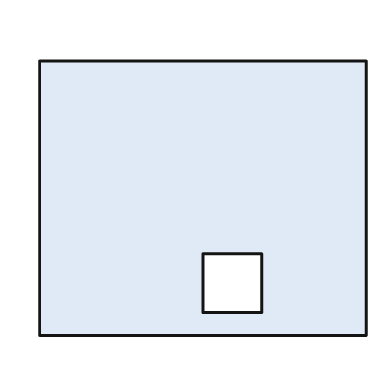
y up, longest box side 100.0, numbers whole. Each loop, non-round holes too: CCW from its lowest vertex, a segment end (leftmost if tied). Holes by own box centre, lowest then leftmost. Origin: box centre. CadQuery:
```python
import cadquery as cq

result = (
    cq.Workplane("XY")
    .moveTo(-50.0, -42.0)
    .lineTo(50.0, -42.0)
    .lineTo(50.0, 42.0)
    .lineTo(-50.0, 42.0)
    .close()
    .moveTo(0.0, -35.0)
    .lineTo(18.0, -35.0)
    .lineTo(18.0, -17.0)
    .lineTo(0.0, -17.0)
    .close()
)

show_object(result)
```